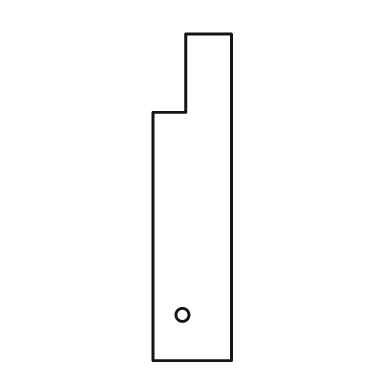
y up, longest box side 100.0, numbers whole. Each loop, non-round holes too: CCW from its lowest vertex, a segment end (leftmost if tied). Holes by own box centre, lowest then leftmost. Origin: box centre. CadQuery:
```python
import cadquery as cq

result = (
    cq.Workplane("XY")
    .moveTo(-12.0, -50.0)
    .lineTo(12.0, -50.0)
    .lineTo(12.0, 50.0)
    .lineTo(-2.0, 50.0)
    .lineTo(-2.0, 26.0)
    .lineTo(-12.0, 26.0)
    .close()
    .moveTo(-3.0, -36.0)
    .circle(2.0)
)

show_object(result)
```